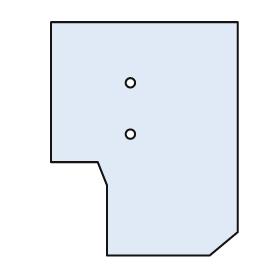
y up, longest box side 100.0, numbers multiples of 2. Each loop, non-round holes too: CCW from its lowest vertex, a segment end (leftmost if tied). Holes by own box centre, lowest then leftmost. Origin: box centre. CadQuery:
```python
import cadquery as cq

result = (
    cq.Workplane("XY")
    .moveTo(-16.0, -50.0)
    .lineTo(28.0, -50.0)
    .lineTo(40.0, -40.0)
    .lineTo(40.0, 50.0)
    .lineTo(-40.0, 50.0)
    .lineTo(-40.0, -10.0)
    .lineTo(-20.0, -10.0)
    .lineTo(-16.0, -20.0)
    .close()
    .moveTo(-6.0, 2.0)
    .circle(2.0)
    .moveTo(-6.0, 24.0)
    .circle(2.0)
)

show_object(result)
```